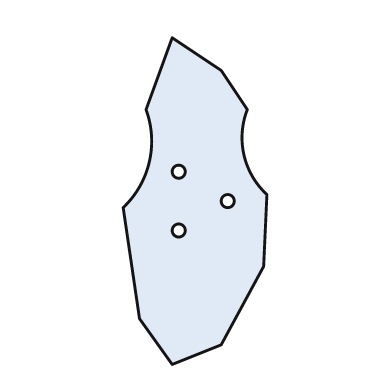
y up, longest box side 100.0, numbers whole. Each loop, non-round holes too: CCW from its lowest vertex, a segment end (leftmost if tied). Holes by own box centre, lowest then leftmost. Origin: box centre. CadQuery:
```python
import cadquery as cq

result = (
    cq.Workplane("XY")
    .moveTo(-7.0, -50.0)
    .lineTo(8.0, -44.0)
    .lineTo(21.0, -20.0)
    .lineTo(22.0, 2.0)
    .threePointArc((15.0, 14.0), (16.0, 28.0))
    .lineTo(8.0, 40.0)
    .lineTo(-7.0, 50.0)
    .lineTo(-15.0, 28.0)
    .threePointArc((-14.0, 12.0), (-22.0, -2.0))
    .lineTo(-17.0, -36.0)
    .close()
    .moveTo(-5.0, -9.0)
    .circle(2.0)
    .moveTo(10.0, 0.0)
    .circle(2.0)
    .moveTo(-5.0, 9.0)
    .circle(2.0)
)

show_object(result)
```